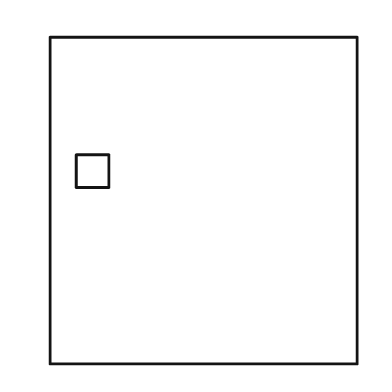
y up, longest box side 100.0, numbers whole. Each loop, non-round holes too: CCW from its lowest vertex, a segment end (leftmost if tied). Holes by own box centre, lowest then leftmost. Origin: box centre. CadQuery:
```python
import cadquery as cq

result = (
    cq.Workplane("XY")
    .moveTo(-47.0, -50.0)
    .lineTo(47.0, -50.0)
    .lineTo(47.0, 50.0)
    .lineTo(-47.0, 50.0)
    .close()
    .moveTo(-39.0, 4.0)
    .lineTo(-29.0, 4.0)
    .lineTo(-29.0, 14.0)
    .lineTo(-39.0, 14.0)
    .close()
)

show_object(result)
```